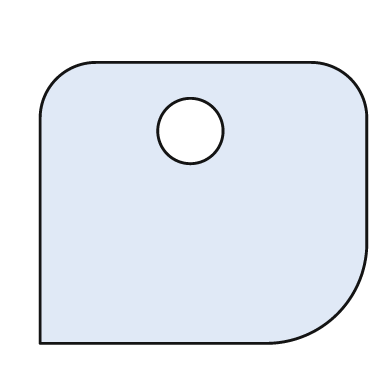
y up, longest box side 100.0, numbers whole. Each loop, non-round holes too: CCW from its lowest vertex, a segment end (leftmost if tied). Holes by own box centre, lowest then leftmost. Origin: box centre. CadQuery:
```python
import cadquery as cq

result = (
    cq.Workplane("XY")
    .moveTo(-50.0, -43.0)
    .lineTo(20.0, -43.0)
    .threePointArc((41.0, -34.0), (50.0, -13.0))
    .lineTo(50.0, 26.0)
    .threePointArc((45.0, 38.0), (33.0, 43.0))
    .lineTo(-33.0, 43.0)
    .threePointArc((-45.0, 38.0), (-50.0, 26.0))
    .close()
    .moveTo(-4.0, 22.0)
    .circle(10.0)
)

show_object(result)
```